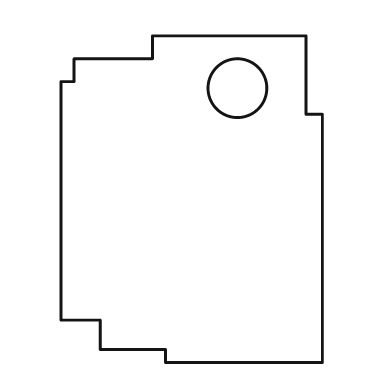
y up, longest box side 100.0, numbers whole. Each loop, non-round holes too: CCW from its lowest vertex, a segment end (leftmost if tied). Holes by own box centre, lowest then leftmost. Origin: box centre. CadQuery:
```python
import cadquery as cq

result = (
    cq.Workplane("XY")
    .moveTo(-8.0, -50.0)
    .lineTo(40.0, -50.0)
    .lineTo(40.0, 26.0)
    .lineTo(35.0, 26.0)
    .lineTo(35.0, 50.0)
    .lineTo(-12.0, 50.0)
    .lineTo(-12.0, 43.0)
    .lineTo(-36.0, 43.0)
    .lineTo(-36.0, 36.0)
    .lineTo(-40.0, 36.0)
    .lineTo(-40.0, -37.0)
    .lineTo(-28.0, -37.0)
    .lineTo(-28.0, -46.0)
    .lineTo(-8.0, -46.0)
    .close()
    .moveTo(14.0, 34.0)
    .circle(9.0)
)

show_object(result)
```